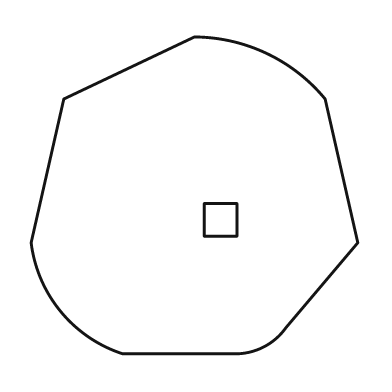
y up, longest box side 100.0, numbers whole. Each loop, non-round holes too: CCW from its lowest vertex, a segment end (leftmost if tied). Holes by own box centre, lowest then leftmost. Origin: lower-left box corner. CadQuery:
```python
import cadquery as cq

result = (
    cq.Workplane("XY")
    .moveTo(28.0, 0.0)
    .lineTo(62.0, 0.0)
    .threePointArc((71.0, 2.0), (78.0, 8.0))
    .lineTo(100.0, 34.0)
    .lineTo(90.0, 78.0)
    .threePointArc((72.0, 92.0), (50.0, 97.0))
    .lineTo(10.0, 78.0)
    .lineTo(0.0, 34.0)
    .threePointArc((9.0, 13.0), (28.0, 0.0))
    .close()
    .moveTo(53.0, 36.0)
    .lineTo(63.0, 36.0)
    .lineTo(63.0, 46.0)
    .lineTo(53.0, 46.0)
    .close()
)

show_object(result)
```